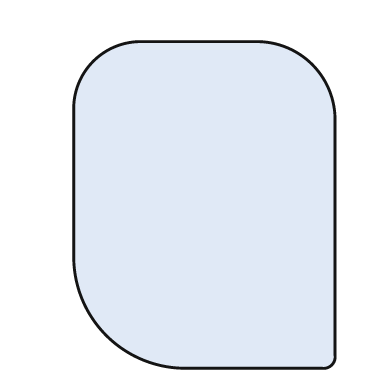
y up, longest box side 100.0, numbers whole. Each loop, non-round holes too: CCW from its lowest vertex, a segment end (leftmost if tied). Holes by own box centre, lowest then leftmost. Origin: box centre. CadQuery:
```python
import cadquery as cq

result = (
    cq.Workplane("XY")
    .moveTo(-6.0, -50.0)
    .lineTo(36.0, -50.0)
    .threePointArc((39.0, -49.0), (40.0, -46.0))
    .lineTo(40.0, 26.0)
    .threePointArc((33.0, 43.0), (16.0, 50.0))
    .lineTo(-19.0, 50.0)
    .threePointArc((-34.0, 44.0), (-40.0, 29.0))
    .lineTo(-40.0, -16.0)
    .threePointArc((-30.0, -40.0), (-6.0, -50.0))
    .close()
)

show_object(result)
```